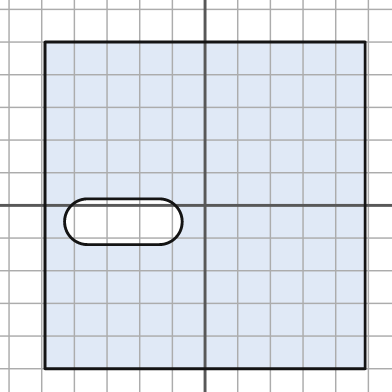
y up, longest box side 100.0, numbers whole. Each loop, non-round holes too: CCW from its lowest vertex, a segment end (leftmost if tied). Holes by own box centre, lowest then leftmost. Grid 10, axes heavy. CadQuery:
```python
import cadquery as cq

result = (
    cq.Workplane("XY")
    .moveTo(-49.0, -50.0)
    .lineTo(49.0, -50.0)
    .lineTo(49.0, 50.0)
    .lineTo(-49.0, 50.0)
    .close()
    .moveTo(-36.0, -12.0)
    .lineTo(-14.0, -12.0)
    .threePointArc((-7.0, -5.0), (-14.0, 2.0))
    .lineTo(-36.0, 2.0)
    .threePointArc((-43.0, -5.0), (-36.0, -12.0))
    .close()
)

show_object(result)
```